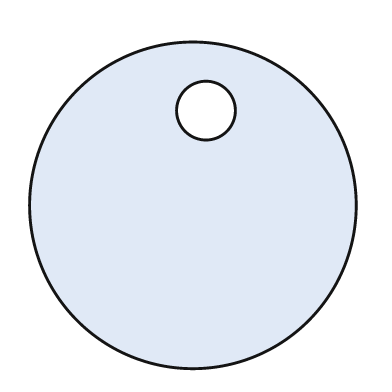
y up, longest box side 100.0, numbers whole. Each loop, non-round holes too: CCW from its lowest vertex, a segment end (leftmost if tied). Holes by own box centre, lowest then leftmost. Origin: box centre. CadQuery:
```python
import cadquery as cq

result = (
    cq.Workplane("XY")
    .moveTo(0.0, 0.0)
    .circle(50.0)
    .moveTo(4.0, 29.0)
    .circle(9.0)
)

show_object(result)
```